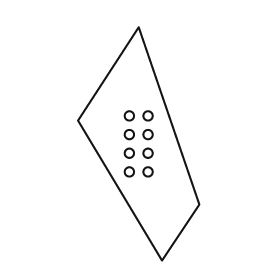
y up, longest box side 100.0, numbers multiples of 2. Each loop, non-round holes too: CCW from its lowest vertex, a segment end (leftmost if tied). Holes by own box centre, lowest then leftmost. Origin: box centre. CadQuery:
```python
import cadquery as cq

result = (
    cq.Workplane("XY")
    .moveTo(10.0, -50.0)
    .lineTo(26.0, -26.0)
    .lineTo(0.0, 50.0)
    .lineTo(-26.0, 10.0)
    .close()
    .moveTo(-4.0, -12.0)
    .circle(2.0)
    .moveTo(4.0, -12.0)
    .circle(2.0)
    .moveTo(-4.0, -4.0)
    .circle(2.0)
    .moveTo(4.0, -4.0)
    .circle(2.0)
    .moveTo(-4.0, 4.0)
    .circle(2.0)
    .moveTo(4.0, 4.0)
    .circle(2.0)
    .moveTo(-4.0, 12.0)
    .circle(2.0)
    .moveTo(4.0, 12.0)
    .circle(2.0)
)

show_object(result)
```